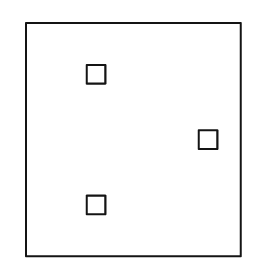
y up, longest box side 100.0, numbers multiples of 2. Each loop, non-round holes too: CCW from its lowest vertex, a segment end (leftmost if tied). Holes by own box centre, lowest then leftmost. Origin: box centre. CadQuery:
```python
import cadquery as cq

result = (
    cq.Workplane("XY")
    .moveTo(-46.0, -50.0)
    .lineTo(46.0, -50.0)
    .lineTo(46.0, 50.0)
    .lineTo(-46.0, 50.0)
    .close()
    .moveTo(-20.0, -32.0)
    .lineTo(-12.0, -32.0)
    .lineTo(-12.0, -24.0)
    .lineTo(-20.0, -24.0)
    .close()
    .moveTo(28.0, -4.0)
    .lineTo(36.0, -4.0)
    .lineTo(36.0, 4.0)
    .lineTo(28.0, 4.0)
    .close()
    .moveTo(-20.0, 24.0)
    .lineTo(-12.0, 24.0)
    .lineTo(-12.0, 32.0)
    .lineTo(-20.0, 32.0)
    .close()
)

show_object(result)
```